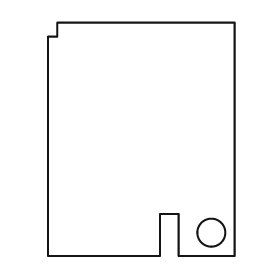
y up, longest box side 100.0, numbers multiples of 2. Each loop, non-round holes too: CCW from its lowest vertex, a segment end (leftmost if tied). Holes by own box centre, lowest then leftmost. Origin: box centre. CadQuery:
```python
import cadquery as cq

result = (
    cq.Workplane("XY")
    .moveTo(-40.0, -50.0)
    .lineTo(8.0, -50.0)
    .lineTo(8.0, -32.0)
    .lineTo(16.0, -32.0)
    .lineTo(16.0, -50.0)
    .lineTo(40.0, -50.0)
    .lineTo(40.0, 50.0)
    .lineTo(-36.0, 50.0)
    .lineTo(-36.0, 44.0)
    .lineTo(-40.0, 44.0)
    .close()
    .moveTo(30.0, -40.0)
    .circle(6.0)
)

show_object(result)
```